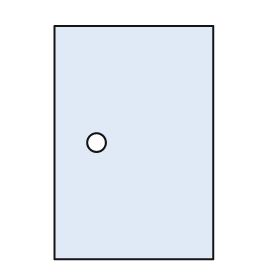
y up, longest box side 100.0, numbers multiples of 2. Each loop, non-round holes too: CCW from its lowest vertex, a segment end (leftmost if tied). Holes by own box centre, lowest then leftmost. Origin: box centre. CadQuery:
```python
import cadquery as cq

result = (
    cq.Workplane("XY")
    .moveTo(-34.0, -50.0)
    .lineTo(34.0, -50.0)
    .lineTo(34.0, 50.0)
    .lineTo(-34.0, 50.0)
    .close()
    .moveTo(-16.0, 0.0)
    .circle(4.0)
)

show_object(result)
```